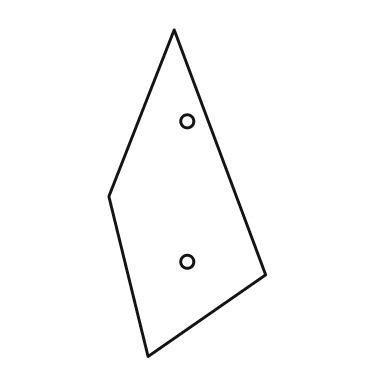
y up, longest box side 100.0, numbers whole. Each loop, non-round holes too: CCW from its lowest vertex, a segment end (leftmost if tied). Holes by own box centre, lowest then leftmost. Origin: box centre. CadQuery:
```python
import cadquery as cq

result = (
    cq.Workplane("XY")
    .moveTo(-12.0, -50.0)
    .lineTo(24.0, -25.0)
    .lineTo(-4.0, 50.0)
    .lineTo(-24.0, -1.0)
    .close()
    .moveTo(0.0, -21.0)
    .circle(2.0)
    .moveTo(0.0, 22.0)
    .circle(2.0)
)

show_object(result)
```